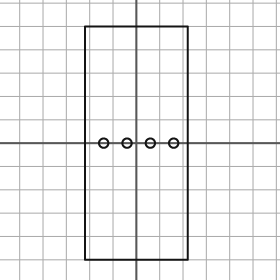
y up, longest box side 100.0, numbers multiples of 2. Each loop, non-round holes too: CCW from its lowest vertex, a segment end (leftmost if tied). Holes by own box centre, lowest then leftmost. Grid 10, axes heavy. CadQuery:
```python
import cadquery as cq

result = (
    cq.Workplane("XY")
    .moveTo(-22.0, -50.0)
    .lineTo(22.0, -50.0)
    .lineTo(22.0, 50.0)
    .lineTo(-22.0, 50.0)
    .close()
    .moveTo(-14.0, 0.0)
    .circle(2.0)
    .moveTo(-4.0, 0.0)
    .circle(2.0)
    .moveTo(6.0, 0.0)
    .circle(2.0)
    .moveTo(16.0, 0.0)
    .circle(2.0)
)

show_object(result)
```